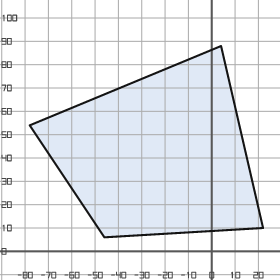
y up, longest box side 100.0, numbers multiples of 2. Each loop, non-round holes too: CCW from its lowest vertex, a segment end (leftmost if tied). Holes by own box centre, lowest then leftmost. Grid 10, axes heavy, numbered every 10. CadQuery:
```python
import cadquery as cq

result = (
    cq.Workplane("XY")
    .moveTo(-46.0, 6.0)
    .lineTo(22.0, 10.0)
    .lineTo(4.0, 88.0)
    .lineTo(-78.0, 54.0)
    .close()
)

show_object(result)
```